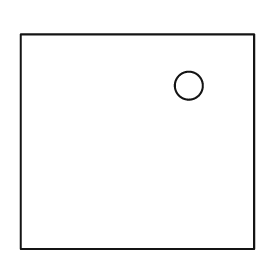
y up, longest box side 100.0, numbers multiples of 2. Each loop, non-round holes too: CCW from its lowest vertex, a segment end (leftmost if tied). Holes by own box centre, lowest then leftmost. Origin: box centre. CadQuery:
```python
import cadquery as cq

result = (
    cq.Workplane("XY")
    .moveTo(-50.0, -46.0)
    .lineTo(50.0, -46.0)
    .lineTo(50.0, 46.0)
    .lineTo(-50.0, 46.0)
    .close()
    .moveTo(22.0, 24.0)
    .circle(6.0)
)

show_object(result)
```